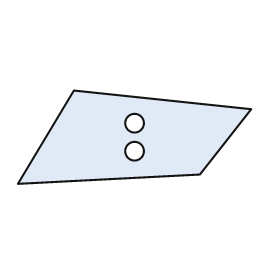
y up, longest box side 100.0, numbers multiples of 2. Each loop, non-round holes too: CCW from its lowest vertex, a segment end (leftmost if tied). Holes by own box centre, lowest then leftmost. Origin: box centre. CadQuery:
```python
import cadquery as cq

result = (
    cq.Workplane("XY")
    .moveTo(-50.0, -20.0)
    .lineTo(28.0, -16.0)
    .lineTo(50.0, 12.0)
    .lineTo(-26.0, 20.0)
    .close()
    .moveTo(0.0, -6.0)
    .circle(4.0)
    .moveTo(0.0, 6.0)
    .circle(4.0)
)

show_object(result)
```